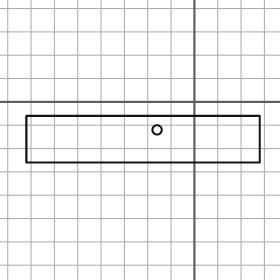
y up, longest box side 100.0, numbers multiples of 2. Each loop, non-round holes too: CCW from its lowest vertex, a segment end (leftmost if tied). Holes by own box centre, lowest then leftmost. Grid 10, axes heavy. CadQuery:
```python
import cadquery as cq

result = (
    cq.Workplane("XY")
    .moveTo(-72.0, -26.0)
    .lineTo(28.0, -26.0)
    .lineTo(28.0, -6.0)
    .lineTo(-72.0, -6.0)
    .close()
    .moveTo(-16.0, -12.0)
    .circle(2.0)
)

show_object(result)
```